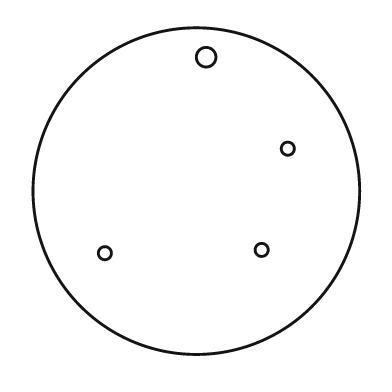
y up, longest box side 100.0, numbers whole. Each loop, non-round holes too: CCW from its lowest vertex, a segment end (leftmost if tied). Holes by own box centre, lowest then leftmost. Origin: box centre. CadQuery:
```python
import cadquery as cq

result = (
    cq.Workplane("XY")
    .moveTo(0.0, 0.0)
    .circle(50.0)
    .moveTo(-28.0, -19.0)
    .circle(2.0)
    .moveTo(20.0, -18.0)
    .circle(2.0)
    .moveTo(28.0, 13.0)
    .circle(2.0)
    .moveTo(3.0, 41.0)
    .circle(3.0)
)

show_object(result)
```